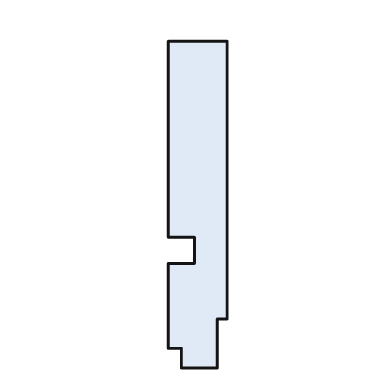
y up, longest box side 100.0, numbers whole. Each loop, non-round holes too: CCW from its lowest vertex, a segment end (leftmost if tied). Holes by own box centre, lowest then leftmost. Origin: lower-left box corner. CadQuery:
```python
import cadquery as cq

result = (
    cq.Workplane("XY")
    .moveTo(4.0, 0.0)
    .lineTo(15.0, 0.0)
    .lineTo(15.0, 15.0)
    .lineTo(18.0, 15.0)
    .lineTo(18.0, 100.0)
    .lineTo(0.0, 100.0)
    .lineTo(0.0, 40.0)
    .lineTo(8.0, 40.0)
    .lineTo(8.0, 32.0)
    .lineTo(0.0, 32.0)
    .lineTo(0.0, 6.0)
    .lineTo(4.0, 6.0)
    .close()
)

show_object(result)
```